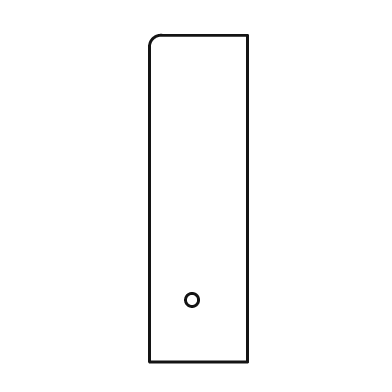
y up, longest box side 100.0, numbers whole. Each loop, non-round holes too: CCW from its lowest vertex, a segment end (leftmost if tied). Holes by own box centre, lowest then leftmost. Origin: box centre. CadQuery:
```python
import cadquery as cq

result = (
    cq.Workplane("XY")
    .moveTo(-15.0, -50.0)
    .lineTo(15.0, -50.0)
    .lineTo(15.0, 50.0)
    .lineTo(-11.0, 50.0)
    .threePointArc((-14.0, 49.0), (-15.0, 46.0))
    .close()
    .moveTo(-2.0, -31.0)
    .circle(2.0)
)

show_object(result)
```